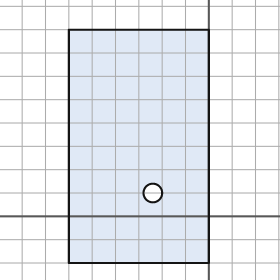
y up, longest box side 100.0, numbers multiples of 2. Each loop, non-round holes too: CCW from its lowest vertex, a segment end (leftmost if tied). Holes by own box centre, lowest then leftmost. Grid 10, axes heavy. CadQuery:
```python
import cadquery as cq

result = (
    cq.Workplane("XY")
    .moveTo(-60.0, -20.0)
    .lineTo(0.0, -20.0)
    .lineTo(0.0, 80.0)
    .lineTo(-60.0, 80.0)
    .close()
    .moveTo(-24.0, 10.0)
    .circle(4.0)
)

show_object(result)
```